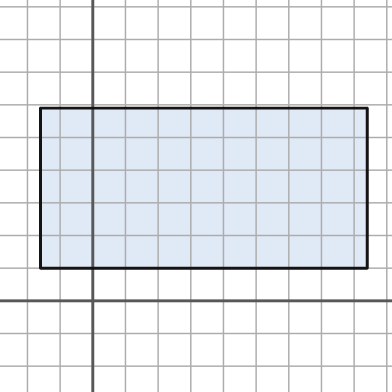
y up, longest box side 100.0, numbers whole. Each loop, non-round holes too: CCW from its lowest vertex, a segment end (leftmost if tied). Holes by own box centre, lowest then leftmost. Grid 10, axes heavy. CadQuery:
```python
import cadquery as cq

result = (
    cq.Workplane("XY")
    .moveTo(-16.0, 10.0)
    .lineTo(84.0, 10.0)
    .lineTo(84.0, 59.0)
    .lineTo(-16.0, 59.0)
    .close()
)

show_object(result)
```